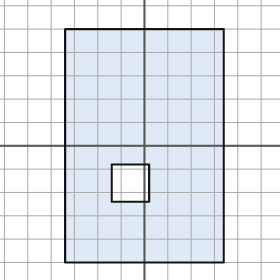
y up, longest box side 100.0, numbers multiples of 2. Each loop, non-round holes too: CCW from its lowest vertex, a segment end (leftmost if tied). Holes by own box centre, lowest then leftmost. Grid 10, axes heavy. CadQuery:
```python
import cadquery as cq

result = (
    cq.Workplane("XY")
    .moveTo(-34.0, -50.0)
    .lineTo(34.0, -50.0)
    .lineTo(34.0, 50.0)
    .lineTo(-34.0, 50.0)
    .close()
    .moveTo(-14.0, -24.0)
    .lineTo(2.0, -24.0)
    .lineTo(2.0, -8.0)
    .lineTo(-14.0, -8.0)
    .close()
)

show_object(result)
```